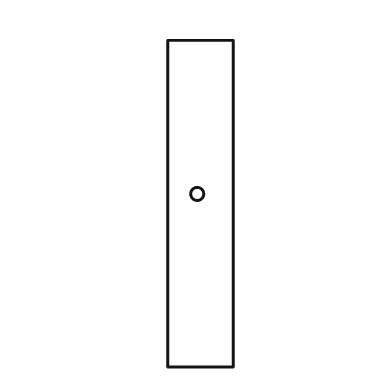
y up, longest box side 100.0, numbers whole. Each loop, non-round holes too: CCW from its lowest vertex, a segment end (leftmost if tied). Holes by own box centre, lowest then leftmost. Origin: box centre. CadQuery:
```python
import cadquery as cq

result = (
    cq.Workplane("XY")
    .moveTo(-10.0, -50.0)
    .lineTo(10.0, -50.0)
    .lineTo(10.0, 50.0)
    .lineTo(-10.0, 50.0)
    .close()
    .moveTo(-1.0, 3.0)
    .circle(2.0)
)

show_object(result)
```